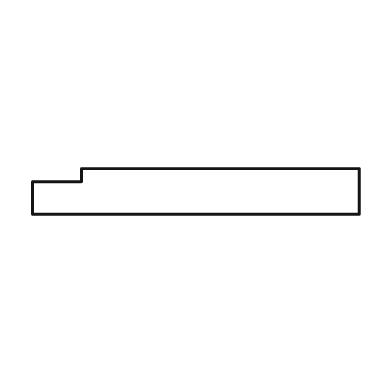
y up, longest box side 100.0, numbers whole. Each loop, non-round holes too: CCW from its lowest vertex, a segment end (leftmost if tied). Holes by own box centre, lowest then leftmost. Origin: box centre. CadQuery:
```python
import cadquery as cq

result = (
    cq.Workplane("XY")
    .moveTo(-50.0, -7.0)
    .lineTo(50.0, -7.0)
    .lineTo(50.0, 7.0)
    .lineTo(-35.0, 7.0)
    .lineTo(-35.0, 3.0)
    .lineTo(-50.0, 3.0)
    .close()
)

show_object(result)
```